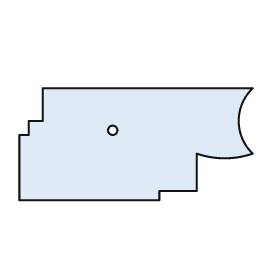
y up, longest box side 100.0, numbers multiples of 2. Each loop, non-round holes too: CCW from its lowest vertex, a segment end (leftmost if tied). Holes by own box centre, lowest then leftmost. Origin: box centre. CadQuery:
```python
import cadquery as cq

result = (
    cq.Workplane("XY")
    .moveTo(-50.0, -24.0)
    .lineTo(10.0, -24.0)
    .lineTo(10.0, -20.0)
    .lineTo(26.0, -20.0)
    .lineTo(26.0, -4.0)
    .threePointArc((38.0, -6.0), (50.0, -4.0))
    .threePointArc((44.0, 10.0), (50.0, 24.0))
    .lineTo(-40.0, 24.0)
    .lineTo(-40.0, 10.0)
    .lineTo(-46.0, 10.0)
    .lineTo(-46.0, 4.0)
    .lineTo(-50.0, 4.0)
    .close()
    .moveTo(-10.0, 6.0)
    .circle(2.0)
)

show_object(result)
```